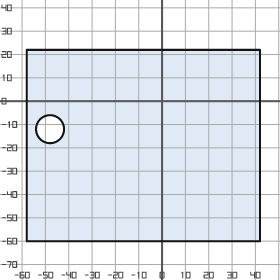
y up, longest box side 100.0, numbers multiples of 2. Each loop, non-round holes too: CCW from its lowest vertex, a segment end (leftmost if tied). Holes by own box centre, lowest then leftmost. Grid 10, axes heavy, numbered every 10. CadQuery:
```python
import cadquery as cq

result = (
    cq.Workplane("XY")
    .moveTo(-58.0, -60.0)
    .lineTo(42.0, -60.0)
    .lineTo(42.0, 22.0)
    .lineTo(-58.0, 22.0)
    .close()
    .moveTo(-48.0, -12.0)
    .circle(6.0)
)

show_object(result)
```